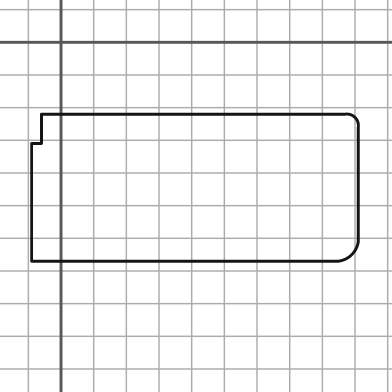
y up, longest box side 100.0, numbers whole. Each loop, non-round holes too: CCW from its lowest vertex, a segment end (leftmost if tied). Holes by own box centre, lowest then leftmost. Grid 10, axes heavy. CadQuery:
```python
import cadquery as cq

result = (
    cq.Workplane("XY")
    .moveTo(-9.0, -67.0)
    .lineTo(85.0, -67.0)
    .threePointArc((89.0, -65.0), (91.0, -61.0))
    .lineTo(91.0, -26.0)
    .threePointArc((90.0, -23.0), (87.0, -22.0))
    .lineTo(-6.0, -22.0)
    .lineTo(-6.0, -31.0)
    .lineTo(-9.0, -31.0)
    .close()
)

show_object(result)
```